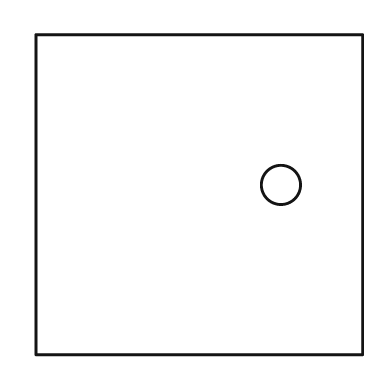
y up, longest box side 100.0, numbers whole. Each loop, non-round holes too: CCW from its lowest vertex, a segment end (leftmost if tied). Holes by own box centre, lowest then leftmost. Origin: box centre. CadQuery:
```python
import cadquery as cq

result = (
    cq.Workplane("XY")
    .moveTo(-50.0, -49.0)
    .lineTo(50.0, -49.0)
    .lineTo(50.0, 49.0)
    .lineTo(-50.0, 49.0)
    .close()
    .moveTo(25.0, 3.0)
    .circle(6.0)
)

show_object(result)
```